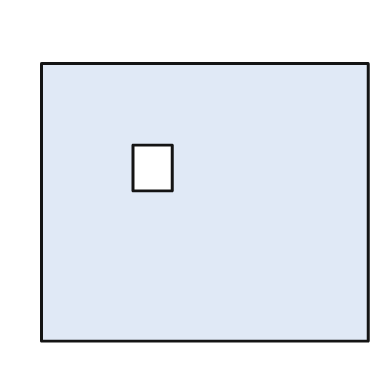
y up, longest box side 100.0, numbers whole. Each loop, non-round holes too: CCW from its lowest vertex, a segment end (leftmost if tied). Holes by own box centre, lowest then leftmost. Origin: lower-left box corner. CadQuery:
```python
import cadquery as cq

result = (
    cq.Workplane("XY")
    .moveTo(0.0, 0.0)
    .lineTo(100.0, 0.0)
    .lineTo(100.0, 85.0)
    .lineTo(0.0, 85.0)
    .close()
    .moveTo(28.0, 46.0)
    .lineTo(40.0, 46.0)
    .lineTo(40.0, 60.0)
    .lineTo(28.0, 60.0)
    .close()
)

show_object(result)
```